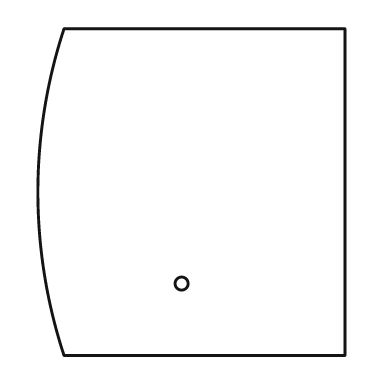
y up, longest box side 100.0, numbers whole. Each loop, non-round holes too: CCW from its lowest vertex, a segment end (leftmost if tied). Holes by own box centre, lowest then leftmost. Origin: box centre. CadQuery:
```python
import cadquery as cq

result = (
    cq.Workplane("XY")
    .moveTo(-39.0, -50.0)
    .lineTo(47.0, -50.0)
    .lineTo(47.0, 50.0)
    .lineTo(-39.0, 50.0)
    .threePointArc((-47.0, 0.0), (-39.0, -50.0))
    .close()
    .moveTo(-3.0, -28.0)
    .circle(2.0)
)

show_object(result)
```